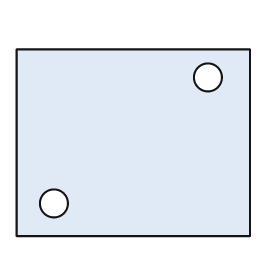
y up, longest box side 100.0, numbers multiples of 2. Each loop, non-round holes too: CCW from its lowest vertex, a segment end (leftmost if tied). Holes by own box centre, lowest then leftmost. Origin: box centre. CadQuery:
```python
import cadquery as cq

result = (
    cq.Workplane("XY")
    .moveTo(-50.0, -40.0)
    .lineTo(50.0, -40.0)
    .lineTo(50.0, 40.0)
    .lineTo(-50.0, 40.0)
    .close()
    .moveTo(-34.0, -26.0)
    .circle(6.0)
    .moveTo(32.0, 28.0)
    .circle(6.0)
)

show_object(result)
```